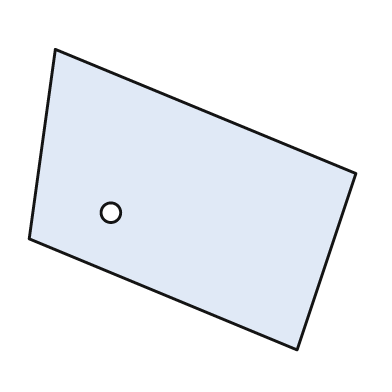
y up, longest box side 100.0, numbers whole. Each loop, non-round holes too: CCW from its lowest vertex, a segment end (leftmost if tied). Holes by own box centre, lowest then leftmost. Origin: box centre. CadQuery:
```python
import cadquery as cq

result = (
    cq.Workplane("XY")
    .moveTo(32.0, -46.0)
    .lineTo(50.0, 8.0)
    .lineTo(-42.0, 46.0)
    .lineTo(-50.0, -12.0)
    .close()
    .moveTo(-25.0, -4.0)
    .circle(3.0)
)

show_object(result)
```